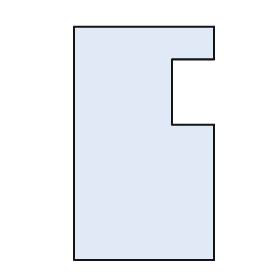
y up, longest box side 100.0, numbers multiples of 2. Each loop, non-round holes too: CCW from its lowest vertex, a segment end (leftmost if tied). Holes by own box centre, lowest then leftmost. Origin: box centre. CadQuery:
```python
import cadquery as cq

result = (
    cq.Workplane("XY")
    .moveTo(-30.0, -50.0)
    .lineTo(30.0, -50.0)
    .lineTo(30.0, 8.0)
    .lineTo(12.0, 8.0)
    .lineTo(12.0, 36.0)
    .lineTo(30.0, 36.0)
    .lineTo(30.0, 50.0)
    .lineTo(-30.0, 50.0)
    .close()
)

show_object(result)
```